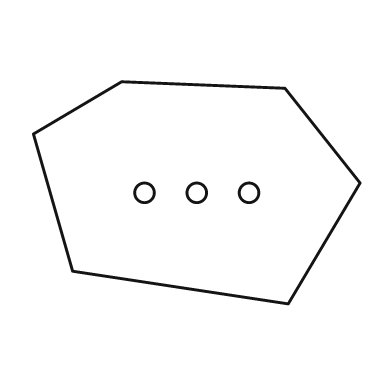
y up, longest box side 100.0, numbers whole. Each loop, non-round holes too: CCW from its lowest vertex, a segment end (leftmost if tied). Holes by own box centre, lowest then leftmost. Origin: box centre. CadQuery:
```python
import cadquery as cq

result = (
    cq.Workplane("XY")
    .moveTo(28.0, -34.0)
    .lineTo(50.0, 3.0)
    .lineTo(27.0, 32.0)
    .lineTo(-23.0, 34.0)
    .lineTo(-50.0, 18.0)
    .lineTo(-38.0, -24.0)
    .close()
    .moveTo(-16.0, 0.0)
    .circle(3.0)
    .moveTo(0.0, 0.0)
    .circle(3.0)
    .moveTo(16.0, 0.0)
    .circle(3.0)
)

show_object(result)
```